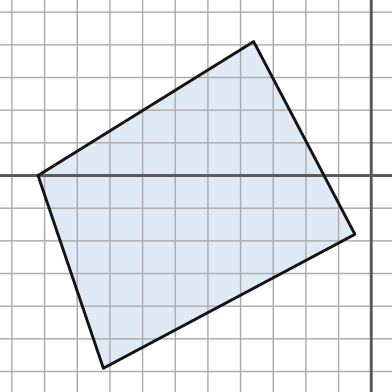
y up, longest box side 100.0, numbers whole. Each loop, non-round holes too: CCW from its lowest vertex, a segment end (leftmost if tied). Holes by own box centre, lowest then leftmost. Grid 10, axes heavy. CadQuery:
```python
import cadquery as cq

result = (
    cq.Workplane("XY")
    .moveTo(-82.0, -59.0)
    .lineTo(-5.0, -18.0)
    .lineTo(-36.0, 41.0)
    .lineTo(-102.0, 0.0)
    .close()
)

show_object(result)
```